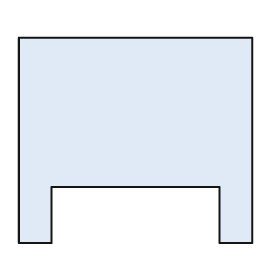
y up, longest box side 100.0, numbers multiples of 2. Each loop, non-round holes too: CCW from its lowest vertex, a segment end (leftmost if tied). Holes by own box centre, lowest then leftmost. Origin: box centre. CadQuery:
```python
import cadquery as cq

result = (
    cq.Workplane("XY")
    .moveTo(-50.0, -44.0)
    .lineTo(-36.0, -44.0)
    .lineTo(-36.0, -20.0)
    .lineTo(36.0, -20.0)
    .lineTo(36.0, -44.0)
    .lineTo(50.0, -44.0)
    .lineTo(50.0, 44.0)
    .lineTo(-50.0, 44.0)
    .close()
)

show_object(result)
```